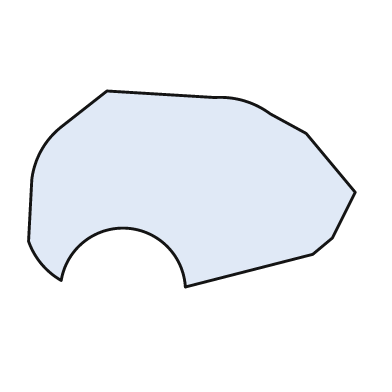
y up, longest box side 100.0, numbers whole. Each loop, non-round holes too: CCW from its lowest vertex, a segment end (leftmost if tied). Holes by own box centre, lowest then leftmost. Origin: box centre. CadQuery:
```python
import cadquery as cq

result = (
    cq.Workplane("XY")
    .moveTo(-2.0, -30.0)
    .lineTo(37.0, -20.0)
    .lineTo(43.0, -15.0)
    .lineTo(50.0, -1.0)
    .lineTo(35.0, 17.0)
    .lineTo(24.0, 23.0)
    .threePointArc((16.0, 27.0), (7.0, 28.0))
    .lineTo(-26.0, 30.0)
    .lineTo(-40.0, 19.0)
    .threePointArc((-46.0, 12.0), (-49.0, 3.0))
    .lineTo(-50.0, -16.0)
    .threePointArc((-46.0, -23.0), (-40.0, -28.0))
    .threePointArc((-20.0, -12.0), (-2.0, -30.0))
    .close()
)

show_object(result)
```